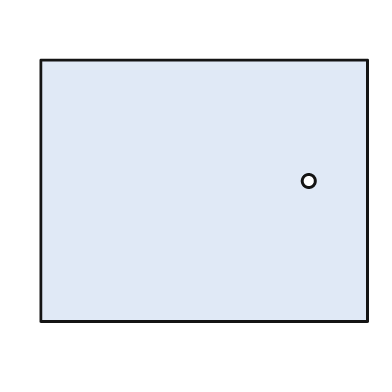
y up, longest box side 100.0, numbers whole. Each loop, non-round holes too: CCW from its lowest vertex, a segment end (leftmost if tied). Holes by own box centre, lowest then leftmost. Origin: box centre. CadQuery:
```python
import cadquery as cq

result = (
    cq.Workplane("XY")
    .moveTo(-50.0, -40.0)
    .lineTo(50.0, -40.0)
    .lineTo(50.0, 40.0)
    .lineTo(-50.0, 40.0)
    .close()
    .moveTo(32.0, 3.0)
    .circle(2.0)
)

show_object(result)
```